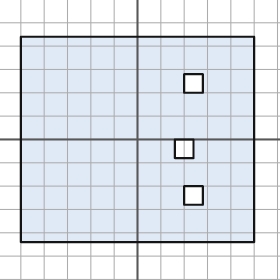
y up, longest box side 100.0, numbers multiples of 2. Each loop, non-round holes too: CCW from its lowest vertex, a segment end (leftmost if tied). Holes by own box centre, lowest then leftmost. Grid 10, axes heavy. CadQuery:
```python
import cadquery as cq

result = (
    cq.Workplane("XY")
    .moveTo(-50.0, -44.0)
    .lineTo(50.0, -44.0)
    .lineTo(50.0, 44.0)
    .lineTo(-50.0, 44.0)
    .close()
    .moveTo(20.0, -28.0)
    .lineTo(28.0, -28.0)
    .lineTo(28.0, -20.0)
    .lineTo(20.0, -20.0)
    .close()
    .moveTo(16.0, -8.0)
    .lineTo(24.0, -8.0)
    .lineTo(24.0, 0.0)
    .lineTo(16.0, 0.0)
    .close()
    .moveTo(20.0, 20.0)
    .lineTo(28.0, 20.0)
    .lineTo(28.0, 28.0)
    .lineTo(20.0, 28.0)
    .close()
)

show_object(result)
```